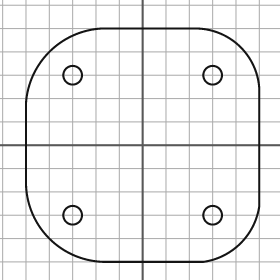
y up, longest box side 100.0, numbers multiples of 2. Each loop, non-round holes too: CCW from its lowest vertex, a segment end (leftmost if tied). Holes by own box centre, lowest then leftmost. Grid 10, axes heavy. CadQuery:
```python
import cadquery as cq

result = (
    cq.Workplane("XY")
    .moveTo(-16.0, -50.0)
    .lineTo(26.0, -50.0)
    .threePointArc((42.0, -42.0), (50.0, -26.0))
    .lineTo(50.0, 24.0)
    .threePointArc((42.0, 42.0), (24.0, 50.0))
    .lineTo(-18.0, 50.0)
    .threePointArc((-40.0, 40.0), (-50.0, 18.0))
    .lineTo(-50.0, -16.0)
    .threePointArc((-40.0, -40.0), (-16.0, -50.0))
    .close()
    .moveTo(-30.0, -30.0)
    .circle(4.0)
    .moveTo(30.0, -30.0)
    .circle(4.0)
    .moveTo(-30.0, 30.0)
    .circle(4.0)
    .moveTo(30.0, 30.0)
    .circle(4.0)
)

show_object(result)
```